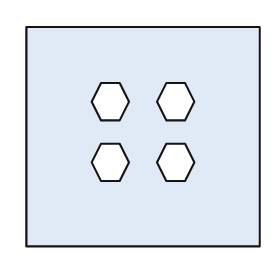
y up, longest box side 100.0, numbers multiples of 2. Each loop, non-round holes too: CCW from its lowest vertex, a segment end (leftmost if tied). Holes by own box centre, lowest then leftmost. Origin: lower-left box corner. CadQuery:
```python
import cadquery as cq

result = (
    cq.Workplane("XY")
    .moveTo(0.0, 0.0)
    .lineTo(100.0, 0.0)
    .lineTo(100.0, 94.0)
    .lineTo(0.0, 94.0)
    .close()
    .moveTo(32.0, 28.0)
    .lineTo(40.0, 28.0)
    .lineTo(44.0, 36.0)
    .lineTo(40.0, 44.0)
    .lineTo(32.0, 44.0)
    .lineTo(28.0, 36.0)
    .close()
    .moveTo(60.0, 28.0)
    .lineTo(68.0, 28.0)
    .lineTo(72.0, 36.0)
    .lineTo(68.0, 44.0)
    .lineTo(60.0, 44.0)
    .lineTo(56.0, 36.0)
    .close()
    .moveTo(32.0, 54.0)
    .lineTo(40.0, 54.0)
    .lineTo(44.0, 62.0)
    .lineTo(40.0, 70.0)
    .lineTo(32.0, 70.0)
    .lineTo(28.0, 62.0)
    .close()
    .moveTo(60.0, 54.0)
    .lineTo(68.0, 54.0)
    .lineTo(72.0, 62.0)
    .lineTo(68.0, 70.0)
    .lineTo(60.0, 70.0)
    .lineTo(56.0, 62.0)
    .close()
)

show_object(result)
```